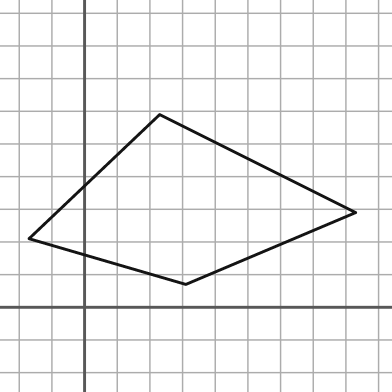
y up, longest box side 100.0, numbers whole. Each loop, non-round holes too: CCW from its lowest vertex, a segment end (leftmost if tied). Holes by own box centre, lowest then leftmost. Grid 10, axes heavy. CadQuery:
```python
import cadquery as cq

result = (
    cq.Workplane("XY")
    .moveTo(31.0, 7.0)
    .lineTo(83.0, 29.0)
    .lineTo(23.0, 59.0)
    .lineTo(-17.0, 21.0)
    .close()
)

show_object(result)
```